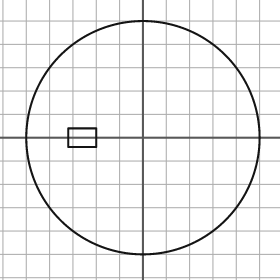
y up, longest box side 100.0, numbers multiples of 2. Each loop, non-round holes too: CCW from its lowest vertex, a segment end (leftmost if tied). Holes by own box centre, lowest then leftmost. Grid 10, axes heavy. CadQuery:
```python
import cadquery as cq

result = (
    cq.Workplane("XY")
    .moveTo(0.0, 0.0)
    .circle(50.0)
    .moveTo(-32.0, -4.0)
    .lineTo(-20.0, -4.0)
    .lineTo(-20.0, 4.0)
    .lineTo(-32.0, 4.0)
    .close()
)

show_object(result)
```